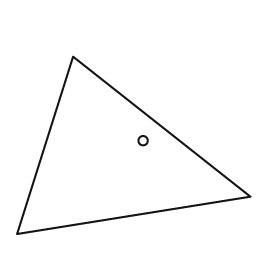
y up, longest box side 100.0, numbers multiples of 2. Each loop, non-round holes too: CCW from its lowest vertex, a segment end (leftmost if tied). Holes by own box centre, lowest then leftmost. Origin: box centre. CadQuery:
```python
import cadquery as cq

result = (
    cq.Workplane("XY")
    .moveTo(-50.0, -38.0)
    .lineTo(50.0, -22.0)
    .lineTo(-26.0, 38.0)
    .close()
    .moveTo(4.0, 2.0)
    .circle(2.0)
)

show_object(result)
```